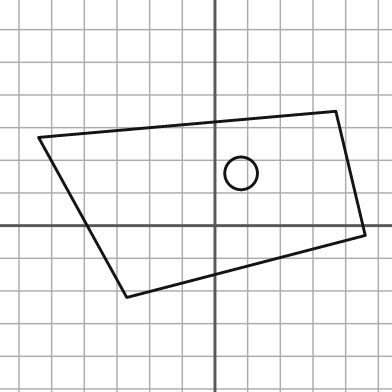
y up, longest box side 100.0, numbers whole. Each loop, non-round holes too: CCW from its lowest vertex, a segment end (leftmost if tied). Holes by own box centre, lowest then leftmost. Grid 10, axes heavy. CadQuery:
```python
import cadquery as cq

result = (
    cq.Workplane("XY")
    .moveTo(-27.0, -22.0)
    .lineTo(46.0, -3.0)
    .lineTo(37.0, 35.0)
    .lineTo(-54.0, 27.0)
    .close()
    .moveTo(8.0, 16.0)
    .circle(5.0)
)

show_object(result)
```